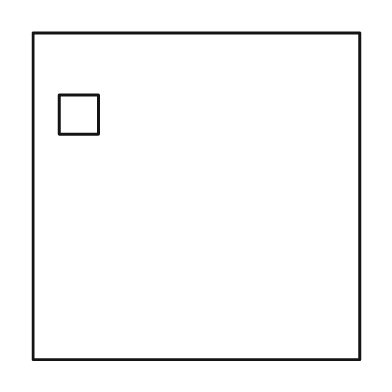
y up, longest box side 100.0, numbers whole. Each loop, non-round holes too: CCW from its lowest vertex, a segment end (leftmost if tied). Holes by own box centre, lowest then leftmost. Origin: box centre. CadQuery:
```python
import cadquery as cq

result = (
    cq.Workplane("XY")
    .moveTo(-50.0, -50.0)
    .lineTo(50.0, -50.0)
    .lineTo(50.0, 50.0)
    .lineTo(-50.0, 50.0)
    .close()
    .moveTo(-42.0, 19.0)
    .lineTo(-30.0, 19.0)
    .lineTo(-30.0, 31.0)
    .lineTo(-42.0, 31.0)
    .close()
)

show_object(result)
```